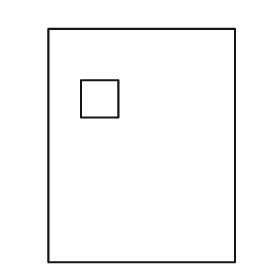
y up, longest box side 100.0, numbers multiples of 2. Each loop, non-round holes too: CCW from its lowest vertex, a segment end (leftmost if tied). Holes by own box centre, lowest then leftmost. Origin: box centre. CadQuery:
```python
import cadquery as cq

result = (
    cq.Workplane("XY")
    .moveTo(-40.0, -50.0)
    .lineTo(40.0, -50.0)
    .lineTo(40.0, 50.0)
    .lineTo(-40.0, 50.0)
    .close()
    .moveTo(-26.0, 12.0)
    .lineTo(-10.0, 12.0)
    .lineTo(-10.0, 28.0)
    .lineTo(-26.0, 28.0)
    .close()
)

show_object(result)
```